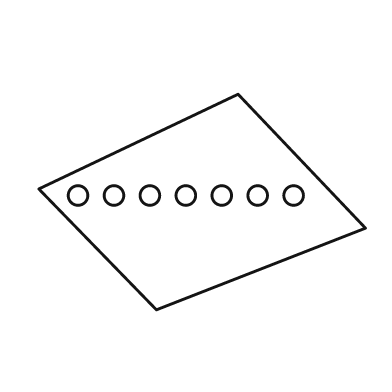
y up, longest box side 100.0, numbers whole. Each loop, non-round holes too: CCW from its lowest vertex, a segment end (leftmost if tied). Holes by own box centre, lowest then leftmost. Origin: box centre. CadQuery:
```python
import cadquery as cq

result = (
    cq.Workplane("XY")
    .moveTo(-14.0, -33.0)
    .lineTo(50.0, -8.0)
    .lineTo(11.0, 33.0)
    .lineTo(-50.0, 4.0)
    .close()
    .moveTo(-38.0, 2.0)
    .circle(3.0)
    .moveTo(-27.0, 2.0)
    .circle(3.0)
    .moveTo(-16.0, 2.0)
    .circle(3.0)
    .moveTo(-5.0, 2.0)
    .circle(3.0)
    .moveTo(6.0, 2.0)
    .circle(3.0)
    .moveTo(17.0, 2.0)
    .circle(3.0)
    .moveTo(28.0, 2.0)
    .circle(3.0)
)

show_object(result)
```